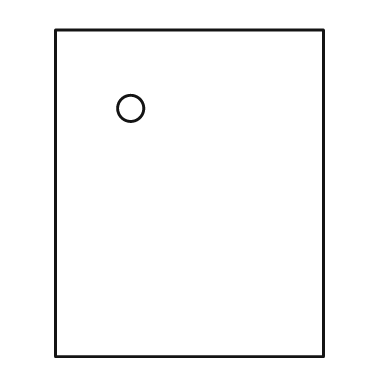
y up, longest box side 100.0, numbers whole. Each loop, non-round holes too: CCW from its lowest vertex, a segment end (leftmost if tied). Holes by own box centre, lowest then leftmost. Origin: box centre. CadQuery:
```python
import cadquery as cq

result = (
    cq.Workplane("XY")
    .moveTo(-41.0, -50.0)
    .lineTo(41.0, -50.0)
    .lineTo(41.0, 50.0)
    .lineTo(-41.0, 50.0)
    .close()
    .moveTo(-18.0, 26.0)
    .circle(4.0)
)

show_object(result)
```